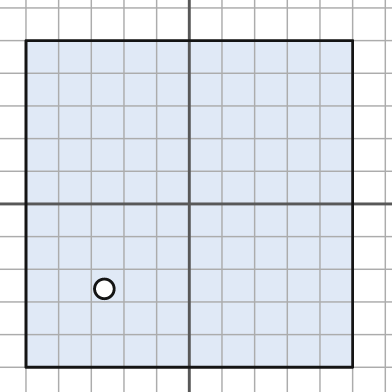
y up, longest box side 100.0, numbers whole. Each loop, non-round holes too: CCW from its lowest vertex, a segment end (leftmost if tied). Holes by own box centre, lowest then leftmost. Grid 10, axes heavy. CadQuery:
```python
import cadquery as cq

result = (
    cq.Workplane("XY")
    .moveTo(-50.0, -50.0)
    .lineTo(50.0, -50.0)
    .lineTo(50.0, 50.0)
    .lineTo(-50.0, 50.0)
    .close()
    .moveTo(-26.0, -26.0)
    .circle(3.0)
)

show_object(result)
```